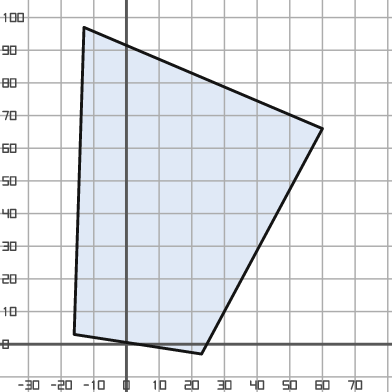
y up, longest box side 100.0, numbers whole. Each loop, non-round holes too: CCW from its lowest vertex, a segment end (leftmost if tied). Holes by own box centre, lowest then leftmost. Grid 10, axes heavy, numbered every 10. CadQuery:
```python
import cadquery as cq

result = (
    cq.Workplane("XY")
    .moveTo(23.0, -3.0)
    .lineTo(60.0, 66.0)
    .lineTo(-13.0, 97.0)
    .lineTo(-16.0, 3.0)
    .close()
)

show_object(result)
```